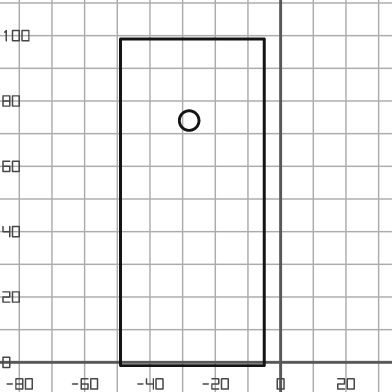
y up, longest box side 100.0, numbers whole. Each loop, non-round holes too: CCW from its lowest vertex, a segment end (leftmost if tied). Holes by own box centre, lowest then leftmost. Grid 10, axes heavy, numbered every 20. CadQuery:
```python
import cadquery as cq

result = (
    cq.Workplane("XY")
    .moveTo(-49.0, -1.0)
    .lineTo(-5.0, -1.0)
    .lineTo(-5.0, 99.0)
    .lineTo(-49.0, 99.0)
    .close()
    .moveTo(-28.0, 74.0)
    .circle(3.0)
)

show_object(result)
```